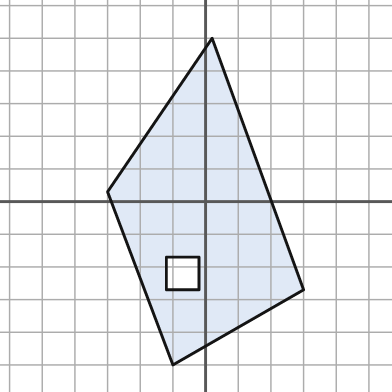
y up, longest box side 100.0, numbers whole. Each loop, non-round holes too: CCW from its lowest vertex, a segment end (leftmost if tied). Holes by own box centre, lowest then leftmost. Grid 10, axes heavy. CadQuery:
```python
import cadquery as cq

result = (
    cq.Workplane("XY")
    .moveTo(-10.0, -50.0)
    .lineTo(30.0, -27.0)
    .lineTo(2.0, 50.0)
    .lineTo(-30.0, 3.0)
    .close()
    .moveTo(-12.0, -27.0)
    .lineTo(-2.0, -27.0)
    .lineTo(-2.0, -17.0)
    .lineTo(-12.0, -17.0)
    .close()
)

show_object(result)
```